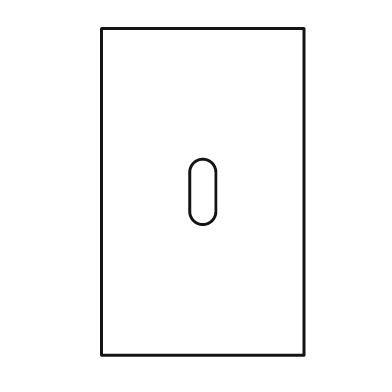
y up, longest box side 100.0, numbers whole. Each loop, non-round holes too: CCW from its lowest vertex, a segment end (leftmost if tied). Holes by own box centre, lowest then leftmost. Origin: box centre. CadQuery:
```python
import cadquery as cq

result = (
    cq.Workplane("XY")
    .moveTo(-31.0, -50.0)
    .lineTo(31.0, -50.0)
    .lineTo(31.0, 50.0)
    .lineTo(-31.0, 50.0)
    .close()
    .moveTo(-4.0, -6.0)
    .threePointArc((0.0, -10.0), (4.0, -6.0))
    .lineTo(4.0, 6.0)
    .threePointArc((0.0, 10.0), (-4.0, 6.0))
    .close()
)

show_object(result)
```